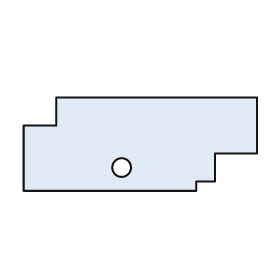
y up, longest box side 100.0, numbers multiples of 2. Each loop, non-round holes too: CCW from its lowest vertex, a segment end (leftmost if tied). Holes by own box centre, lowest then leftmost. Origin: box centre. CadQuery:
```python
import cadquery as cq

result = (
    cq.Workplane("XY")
    .moveTo(-50.0, -20.0)
    .lineTo(24.0, -20.0)
    .lineTo(24.0, -16.0)
    .lineTo(32.0, -16.0)
    .lineTo(32.0, -4.0)
    .lineTo(50.0, -4.0)
    .lineTo(50.0, 20.0)
    .lineTo(-36.0, 20.0)
    .lineTo(-36.0, 8.0)
    .lineTo(-50.0, 8.0)
    .close()
    .moveTo(-8.0, -10.0)
    .circle(4.0)
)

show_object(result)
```